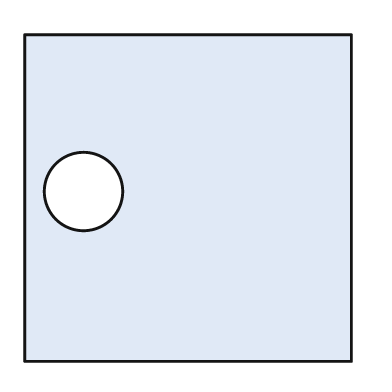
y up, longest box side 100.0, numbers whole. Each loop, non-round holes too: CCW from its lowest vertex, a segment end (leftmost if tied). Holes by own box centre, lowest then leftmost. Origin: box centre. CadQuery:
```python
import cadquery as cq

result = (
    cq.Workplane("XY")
    .moveTo(-50.0, -50.0)
    .lineTo(50.0, -50.0)
    .lineTo(50.0, 50.0)
    .lineTo(-50.0, 50.0)
    .close()
    .moveTo(-32.0, 2.0)
    .circle(12.0)
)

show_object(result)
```